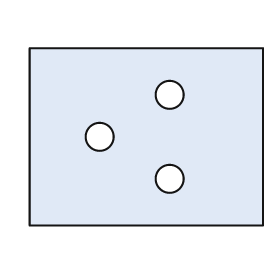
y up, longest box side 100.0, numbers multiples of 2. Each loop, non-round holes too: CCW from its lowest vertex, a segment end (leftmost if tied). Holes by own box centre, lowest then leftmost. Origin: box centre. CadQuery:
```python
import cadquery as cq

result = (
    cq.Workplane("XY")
    .moveTo(-50.0, -38.0)
    .lineTo(50.0, -38.0)
    .lineTo(50.0, 38.0)
    .lineTo(-50.0, 38.0)
    .close()
    .moveTo(10.0, -18.0)
    .circle(6.0)
    .moveTo(-20.0, 0.0)
    .circle(6.0)
    .moveTo(10.0, 18.0)
    .circle(6.0)
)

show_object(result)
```